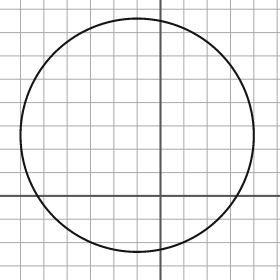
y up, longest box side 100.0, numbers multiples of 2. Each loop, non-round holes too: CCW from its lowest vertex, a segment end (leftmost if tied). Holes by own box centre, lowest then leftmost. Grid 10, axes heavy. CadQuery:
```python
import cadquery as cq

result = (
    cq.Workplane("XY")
    .moveTo(-10.0, 26.0)
    .circle(50.0)
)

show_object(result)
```